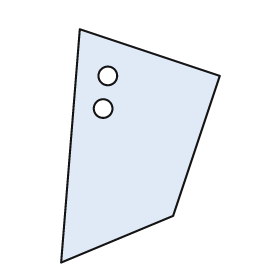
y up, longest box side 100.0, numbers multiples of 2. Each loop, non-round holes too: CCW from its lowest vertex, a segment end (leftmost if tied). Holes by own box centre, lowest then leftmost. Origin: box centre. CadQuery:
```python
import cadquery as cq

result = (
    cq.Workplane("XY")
    .moveTo(-34.0, -50.0)
    .lineTo(14.0, -30.0)
    .lineTo(34.0, 30.0)
    .lineTo(-26.0, 50.0)
    .close()
    .moveTo(-16.0, 16.0)
    .circle(4.0)
    .moveTo(-14.0, 30.0)
    .circle(4.0)
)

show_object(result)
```